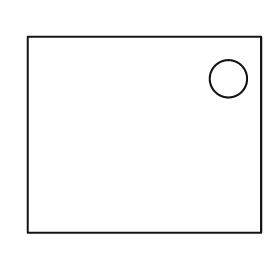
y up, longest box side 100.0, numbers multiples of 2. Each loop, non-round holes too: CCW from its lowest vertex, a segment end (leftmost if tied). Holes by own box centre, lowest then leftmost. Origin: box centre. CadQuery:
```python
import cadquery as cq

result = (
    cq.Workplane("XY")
    .moveTo(-50.0, -42.0)
    .lineTo(50.0, -42.0)
    .lineTo(50.0, 42.0)
    .lineTo(-50.0, 42.0)
    .close()
    .moveTo(36.0, 24.0)
    .circle(8.0)
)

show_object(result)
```